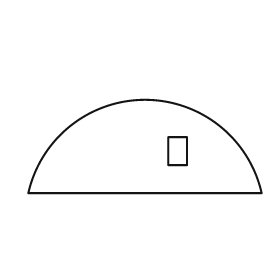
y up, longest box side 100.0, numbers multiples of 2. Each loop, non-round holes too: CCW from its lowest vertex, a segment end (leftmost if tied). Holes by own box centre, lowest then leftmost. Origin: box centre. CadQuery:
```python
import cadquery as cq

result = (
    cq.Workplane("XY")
    .moveTo(-50.0, -20.0)
    .lineTo(50.0, -20.0)
    .threePointArc((0.0, 20.0), (-50.0, -20.0))
    .close()
    .moveTo(10.0, -8.0)
    .lineTo(18.0, -8.0)
    .lineTo(18.0, 4.0)
    .lineTo(10.0, 4.0)
    .close()
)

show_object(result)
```